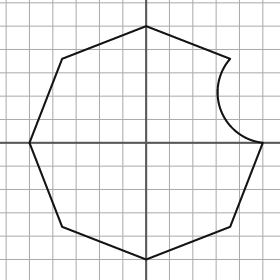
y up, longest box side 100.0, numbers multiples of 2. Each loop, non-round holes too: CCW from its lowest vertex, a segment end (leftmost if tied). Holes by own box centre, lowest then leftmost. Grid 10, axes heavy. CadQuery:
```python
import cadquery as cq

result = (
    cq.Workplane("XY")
    .moveTo(0.0, -50.0)
    .lineTo(36.0, -36.0)
    .lineTo(50.0, 0.0)
    .threePointArc((32.0, 14.0), (36.0, 36.0))
    .lineTo(0.0, 50.0)
    .lineTo(-36.0, 36.0)
    .lineTo(-50.0, 0.0)
    .lineTo(-36.0, -36.0)
    .close()
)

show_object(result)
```